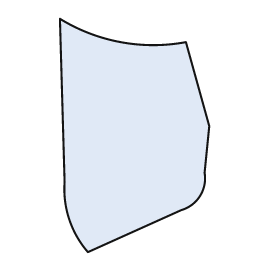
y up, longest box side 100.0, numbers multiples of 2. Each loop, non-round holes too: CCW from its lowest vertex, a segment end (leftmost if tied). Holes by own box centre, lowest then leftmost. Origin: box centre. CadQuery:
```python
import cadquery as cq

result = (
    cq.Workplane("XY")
    .moveTo(-20.0, -50.0)
    .lineTo(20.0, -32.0)
    .threePointArc((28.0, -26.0), (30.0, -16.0))
    .lineTo(32.0, 4.0)
    .lineTo(22.0, 40.0)
    .threePointArc((-6.0, 40.0), (-32.0, 50.0))
    .lineTo(-30.0, -20.0)
    .threePointArc((-28.0, -36.0), (-20.0, -50.0))
    .close()
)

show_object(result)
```